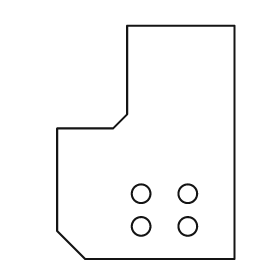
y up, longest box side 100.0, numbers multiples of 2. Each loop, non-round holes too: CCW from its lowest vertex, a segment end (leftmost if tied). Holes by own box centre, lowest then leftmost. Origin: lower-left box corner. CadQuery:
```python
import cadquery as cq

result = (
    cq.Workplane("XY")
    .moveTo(12.0, 0.0)
    .lineTo(76.0, 0.0)
    .lineTo(76.0, 100.0)
    .lineTo(30.0, 100.0)
    .lineTo(30.0, 62.0)
    .lineTo(24.0, 56.0)
    .lineTo(0.0, 56.0)
    .lineTo(0.0, 12.0)
    .close()
    .moveTo(36.0, 14.0)
    .circle(4.0)
    .moveTo(56.0, 14.0)
    .circle(4.0)
    .moveTo(36.0, 28.0)
    .circle(4.0)
    .moveTo(56.0, 28.0)
    .circle(4.0)
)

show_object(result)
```